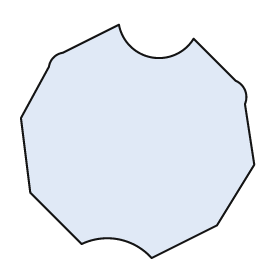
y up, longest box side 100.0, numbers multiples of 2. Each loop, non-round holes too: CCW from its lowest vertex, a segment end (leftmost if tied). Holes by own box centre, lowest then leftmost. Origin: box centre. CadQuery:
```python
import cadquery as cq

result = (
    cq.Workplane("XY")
    .moveTo(6.0, -50.0)
    .lineTo(34.0, -36.0)
    .lineTo(50.0, -10.0)
    .lineTo(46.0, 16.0)
    .threePointArc((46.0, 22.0), (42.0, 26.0))
    .lineTo(24.0, 44.0)
    .threePointArc((6.0, 36.0), (-8.0, 50.0))
    .lineTo(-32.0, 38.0)
    .threePointArc((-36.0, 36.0), (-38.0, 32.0))
    .lineTo(-50.0, 10.0)
    .lineTo(-46.0, -22.0)
    .lineTo(-24.0, -44.0)
    .threePointArc((-8.0, -42.0), (6.0, -50.0))
    .close()
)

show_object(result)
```